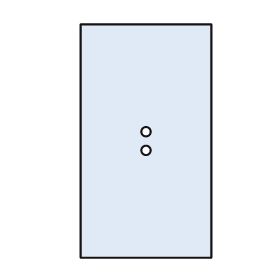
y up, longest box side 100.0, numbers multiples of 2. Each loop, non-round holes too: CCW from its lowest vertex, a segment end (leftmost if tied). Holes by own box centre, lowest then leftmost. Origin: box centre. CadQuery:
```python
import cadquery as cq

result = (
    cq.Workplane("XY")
    .moveTo(-28.0, -50.0)
    .lineTo(28.0, -50.0)
    .lineTo(28.0, 50.0)
    .lineTo(-28.0, 50.0)
    .close()
    .moveTo(0.0, -4.0)
    .circle(2.0)
    .moveTo(0.0, 4.0)
    .circle(2.0)
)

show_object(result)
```